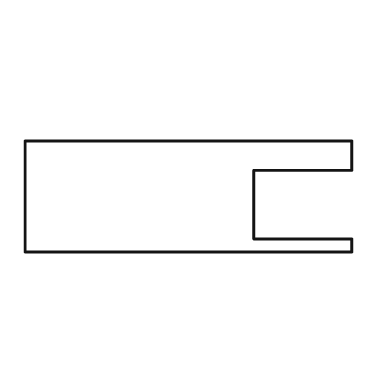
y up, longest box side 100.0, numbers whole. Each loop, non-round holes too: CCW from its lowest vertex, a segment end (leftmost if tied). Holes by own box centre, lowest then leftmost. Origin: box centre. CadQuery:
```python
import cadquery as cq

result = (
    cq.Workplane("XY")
    .moveTo(-50.0, -17.0)
    .lineTo(50.0, -17.0)
    .lineTo(50.0, -13.0)
    .lineTo(20.0, -13.0)
    .lineTo(20.0, 8.0)
    .lineTo(50.0, 8.0)
    .lineTo(50.0, 17.0)
    .lineTo(-50.0, 17.0)
    .close()
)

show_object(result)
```